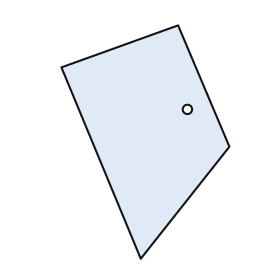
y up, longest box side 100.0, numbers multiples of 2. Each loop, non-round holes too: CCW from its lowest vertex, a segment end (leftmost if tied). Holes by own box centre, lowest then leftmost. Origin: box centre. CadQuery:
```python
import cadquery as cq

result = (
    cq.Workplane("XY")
    .moveTo(-2.0, -50.0)
    .lineTo(36.0, -2.0)
    .lineTo(14.0, 50.0)
    .lineTo(-36.0, 32.0)
    .close()
    .moveTo(18.0, 14.0)
    .circle(2.0)
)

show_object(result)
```